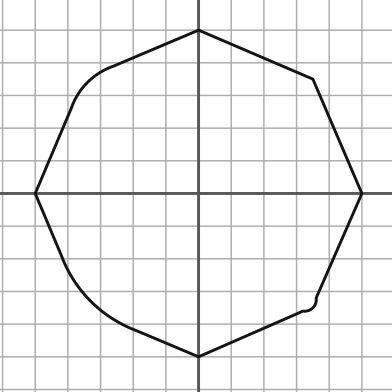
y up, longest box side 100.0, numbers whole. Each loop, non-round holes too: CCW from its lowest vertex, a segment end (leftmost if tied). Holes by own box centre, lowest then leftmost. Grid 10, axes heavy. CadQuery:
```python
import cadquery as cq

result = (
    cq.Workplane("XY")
    .moveTo(0.0, -50.0)
    .lineTo(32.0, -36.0)
    .threePointArc((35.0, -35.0), (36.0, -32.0))
    .lineTo(50.0, 0.0)
    .lineTo(35.0, 35.0)
    .lineTo(0.0, 50.0)
    .lineTo(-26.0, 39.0)
    .threePointArc((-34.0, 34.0), (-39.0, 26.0))
    .lineTo(-50.0, 0.0)
    .lineTo(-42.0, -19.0)
    .threePointArc((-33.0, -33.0), (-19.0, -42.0))
    .close()
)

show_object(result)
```